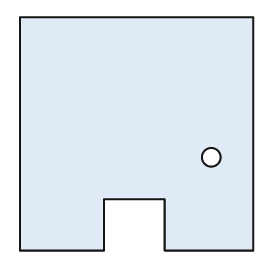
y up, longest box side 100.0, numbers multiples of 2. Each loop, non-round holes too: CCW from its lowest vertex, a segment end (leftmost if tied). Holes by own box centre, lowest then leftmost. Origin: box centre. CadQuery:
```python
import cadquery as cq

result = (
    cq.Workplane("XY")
    .moveTo(-50.0, -50.0)
    .lineTo(-14.0, -50.0)
    .lineTo(-14.0, -28.0)
    .lineTo(12.0, -28.0)
    .lineTo(12.0, -50.0)
    .lineTo(50.0, -50.0)
    .lineTo(50.0, 50.0)
    .lineTo(-50.0, 50.0)
    .close()
    .moveTo(32.0, -10.0)
    .circle(4.0)
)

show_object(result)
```